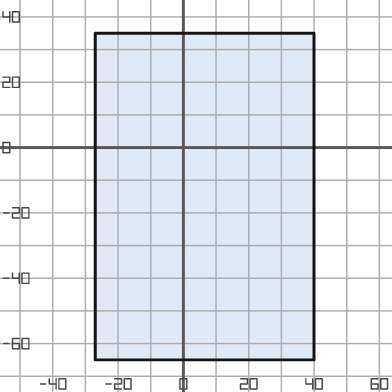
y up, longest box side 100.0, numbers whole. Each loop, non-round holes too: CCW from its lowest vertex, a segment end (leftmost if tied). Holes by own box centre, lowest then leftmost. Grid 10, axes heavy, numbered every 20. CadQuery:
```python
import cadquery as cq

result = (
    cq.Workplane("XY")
    .moveTo(-27.0, -65.0)
    .lineTo(40.0, -65.0)
    .lineTo(40.0, 35.0)
    .lineTo(-27.0, 35.0)
    .close()
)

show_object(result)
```